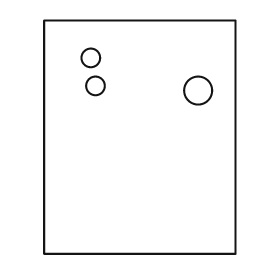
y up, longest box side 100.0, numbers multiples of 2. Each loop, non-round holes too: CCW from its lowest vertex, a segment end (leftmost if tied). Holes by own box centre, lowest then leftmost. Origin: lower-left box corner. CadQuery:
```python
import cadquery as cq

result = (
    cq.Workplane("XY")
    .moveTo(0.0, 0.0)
    .lineTo(82.0, 0.0)
    .lineTo(82.0, 100.0)
    .lineTo(0.0, 100.0)
    .close()
    .moveTo(66.0, 70.0)
    .circle(6.0)
    .moveTo(22.0, 72.0)
    .circle(4.0)
    .moveTo(20.0, 84.0)
    .circle(4.0)
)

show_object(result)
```